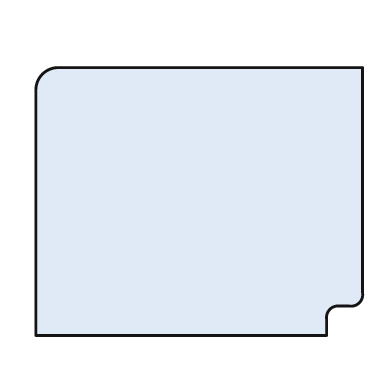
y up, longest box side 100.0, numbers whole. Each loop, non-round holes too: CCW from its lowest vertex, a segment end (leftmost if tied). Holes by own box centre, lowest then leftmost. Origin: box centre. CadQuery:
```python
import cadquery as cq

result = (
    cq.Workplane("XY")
    .moveTo(-50.0, -41.0)
    .lineTo(39.0, -41.0)
    .lineTo(39.0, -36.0)
    .threePointArc((40.0, -33.0), (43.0, -32.0))
    .lineTo(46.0, -32.0)
    .threePointArc((49.0, -31.0), (50.0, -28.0))
    .lineTo(50.0, 41.0)
    .lineTo(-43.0, 41.0)
    .threePointArc((-48.0, 39.0), (-50.0, 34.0))
    .close()
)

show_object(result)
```